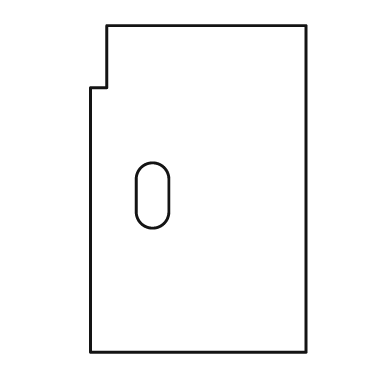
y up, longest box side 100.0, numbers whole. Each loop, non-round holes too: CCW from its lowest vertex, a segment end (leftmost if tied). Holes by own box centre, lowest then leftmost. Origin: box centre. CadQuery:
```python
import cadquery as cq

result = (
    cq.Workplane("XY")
    .moveTo(-33.0, -50.0)
    .lineTo(33.0, -50.0)
    .lineTo(33.0, 50.0)
    .lineTo(-28.0, 50.0)
    .lineTo(-28.0, 31.0)
    .lineTo(-33.0, 31.0)
    .close()
    .moveTo(-19.0, -7.0)
    .threePointArc((-14.0, -12.0), (-9.0, -7.0))
    .lineTo(-9.0, 3.0)
    .threePointArc((-14.0, 8.0), (-19.0, 3.0))
    .close()
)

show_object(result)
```